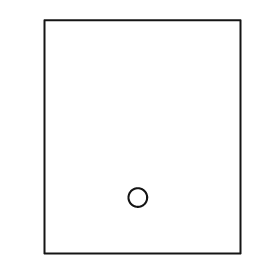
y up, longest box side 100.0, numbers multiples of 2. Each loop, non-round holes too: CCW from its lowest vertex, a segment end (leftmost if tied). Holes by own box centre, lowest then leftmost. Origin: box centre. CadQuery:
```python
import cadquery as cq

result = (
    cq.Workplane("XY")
    .moveTo(-42.0, -50.0)
    .lineTo(42.0, -50.0)
    .lineTo(42.0, 50.0)
    .lineTo(-42.0, 50.0)
    .close()
    .moveTo(-2.0, -26.0)
    .circle(4.0)
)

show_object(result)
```